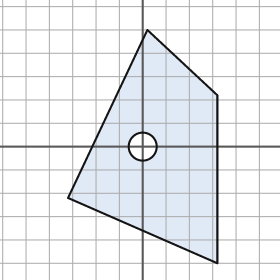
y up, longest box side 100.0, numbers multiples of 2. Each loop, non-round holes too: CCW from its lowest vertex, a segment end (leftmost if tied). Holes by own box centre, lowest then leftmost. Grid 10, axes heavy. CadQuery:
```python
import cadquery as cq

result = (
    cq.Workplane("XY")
    .moveTo(32.0, -50.0)
    .lineTo(32.0, 22.0)
    .lineTo(2.0, 50.0)
    .lineTo(-32.0, -22.0)
    .close()
    .moveTo(0.0, 0.0)
    .circle(6.0)
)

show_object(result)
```